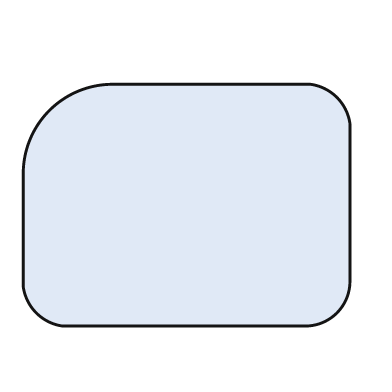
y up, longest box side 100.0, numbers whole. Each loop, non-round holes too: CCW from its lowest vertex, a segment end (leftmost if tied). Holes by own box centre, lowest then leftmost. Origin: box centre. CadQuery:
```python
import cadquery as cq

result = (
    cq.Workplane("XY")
    .moveTo(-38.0, -37.0)
    .lineTo(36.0, -37.0)
    .threePointArc((46.0, -33.0), (50.0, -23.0))
    .lineTo(50.0, 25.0)
    .threePointArc((46.0, 33.0), (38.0, 37.0))
    .lineTo(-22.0, 37.0)
    .threePointArc((-42.0, 29.0), (-50.0, 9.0))
    .lineTo(-50.0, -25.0)
    .threePointArc((-46.0, -33.0), (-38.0, -37.0))
    .close()
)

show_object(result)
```